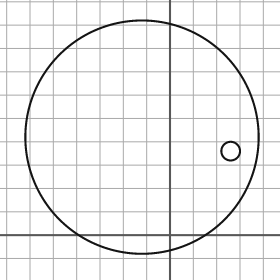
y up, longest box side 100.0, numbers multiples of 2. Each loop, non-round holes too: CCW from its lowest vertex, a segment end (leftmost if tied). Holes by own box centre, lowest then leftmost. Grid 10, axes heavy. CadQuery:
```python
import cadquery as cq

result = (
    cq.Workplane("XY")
    .moveTo(-12.0, 42.0)
    .circle(50.0)
    .moveTo(26.0, 36.0)
    .circle(4.0)
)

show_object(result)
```